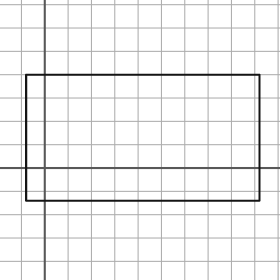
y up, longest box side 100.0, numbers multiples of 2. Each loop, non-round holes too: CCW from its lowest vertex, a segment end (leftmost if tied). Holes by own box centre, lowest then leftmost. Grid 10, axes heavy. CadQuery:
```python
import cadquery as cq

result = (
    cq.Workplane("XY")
    .moveTo(-8.0, -14.0)
    .lineTo(92.0, -14.0)
    .lineTo(92.0, 40.0)
    .lineTo(-8.0, 40.0)
    .close()
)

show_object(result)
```